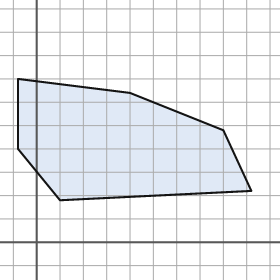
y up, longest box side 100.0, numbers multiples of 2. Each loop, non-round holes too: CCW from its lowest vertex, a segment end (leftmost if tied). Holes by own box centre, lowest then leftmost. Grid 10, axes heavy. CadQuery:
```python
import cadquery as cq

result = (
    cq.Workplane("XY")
    .moveTo(10.0, 18.0)
    .lineTo(92.0, 22.0)
    .lineTo(80.0, 48.0)
    .lineTo(40.0, 64.0)
    .lineTo(-8.0, 70.0)
    .lineTo(-8.0, 40.0)
    .close()
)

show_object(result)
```